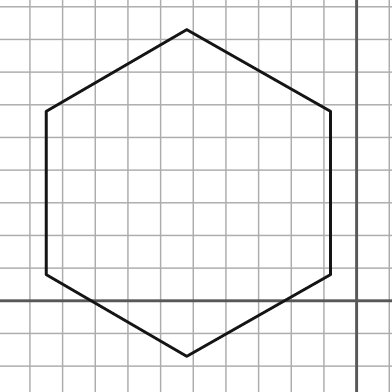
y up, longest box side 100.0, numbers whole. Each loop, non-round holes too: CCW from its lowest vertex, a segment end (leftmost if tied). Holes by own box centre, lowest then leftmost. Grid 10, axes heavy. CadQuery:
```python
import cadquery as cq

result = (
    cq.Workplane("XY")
    .moveTo(-52.0, -17.0)
    .lineTo(-8.0, 8.0)
    .lineTo(-8.0, 58.0)
    .lineTo(-52.0, 83.0)
    .lineTo(-95.0, 58.0)
    .lineTo(-95.0, 8.0)
    .close()
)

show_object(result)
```